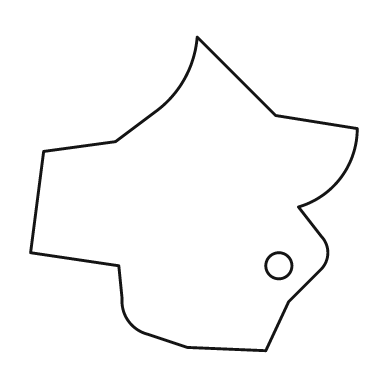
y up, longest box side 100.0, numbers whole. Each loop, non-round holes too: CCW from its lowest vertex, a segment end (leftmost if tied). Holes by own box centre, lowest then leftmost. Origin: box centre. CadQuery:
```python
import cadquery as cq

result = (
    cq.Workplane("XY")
    .moveTo(22.0, -48.0)
    .lineTo(29.0, -33.0)
    .lineTo(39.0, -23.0)
    .threePointArc((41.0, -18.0), (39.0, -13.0))
    .lineTo(32.0, -4.0)
    .threePointArc((45.0, 5.0), (50.0, 20.0))
    .lineTo(25.0, 24.0)
    .lineTo(1.0, 48.0)
    .threePointArc((-3.0, 35.0), (-12.0, 25.0))
    .lineTo(-24.0, 16.0)
    .lineTo(-46.0, 13.0)
    .lineTo(-50.0, -18.0)
    .lineTo(-23.0, -22.0)
    .lineTo(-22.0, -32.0)
    .threePointArc((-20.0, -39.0), (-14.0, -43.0))
    .lineTo(-2.0, -47.0)
    .close()
    .moveTo(26.0, -22.0)
    .circle(4.0)
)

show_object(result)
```